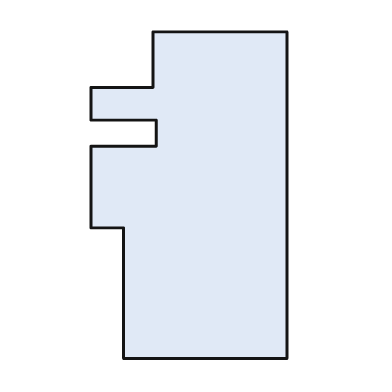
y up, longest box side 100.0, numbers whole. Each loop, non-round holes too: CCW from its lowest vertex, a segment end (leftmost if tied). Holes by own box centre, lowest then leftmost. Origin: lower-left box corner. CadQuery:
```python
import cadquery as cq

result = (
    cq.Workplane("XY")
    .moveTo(10.0, 0.0)
    .lineTo(60.0, 0.0)
    .lineTo(60.0, 100.0)
    .lineTo(19.0, 100.0)
    .lineTo(19.0, 83.0)
    .lineTo(0.0, 83.0)
    .lineTo(0.0, 73.0)
    .lineTo(20.0, 73.0)
    .lineTo(20.0, 65.0)
    .lineTo(0.0, 65.0)
    .lineTo(0.0, 40.0)
    .lineTo(10.0, 40.0)
    .close()
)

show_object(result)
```